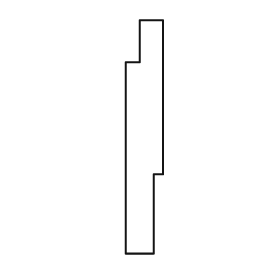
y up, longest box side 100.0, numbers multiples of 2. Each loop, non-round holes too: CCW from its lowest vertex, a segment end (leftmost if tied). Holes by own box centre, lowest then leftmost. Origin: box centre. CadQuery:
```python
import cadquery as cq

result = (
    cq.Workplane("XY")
    .moveTo(-8.0, -50.0)
    .lineTo(4.0, -50.0)
    .lineTo(4.0, -16.0)
    .lineTo(8.0, -16.0)
    .lineTo(8.0, 50.0)
    .lineTo(-2.0, 50.0)
    .lineTo(-2.0, 32.0)
    .lineTo(-8.0, 32.0)
    .close()
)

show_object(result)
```